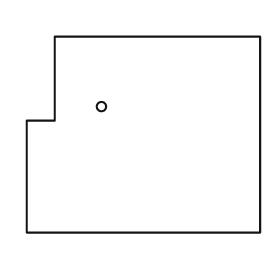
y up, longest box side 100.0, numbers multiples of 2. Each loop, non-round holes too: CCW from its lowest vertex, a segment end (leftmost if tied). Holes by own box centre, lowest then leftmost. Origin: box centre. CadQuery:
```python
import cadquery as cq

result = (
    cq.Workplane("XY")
    .moveTo(-50.0, -42.0)
    .lineTo(50.0, -42.0)
    .lineTo(50.0, 42.0)
    .lineTo(-38.0, 42.0)
    .lineTo(-38.0, 6.0)
    .lineTo(-50.0, 6.0)
    .close()
    .moveTo(-18.0, 12.0)
    .circle(2.0)
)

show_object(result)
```